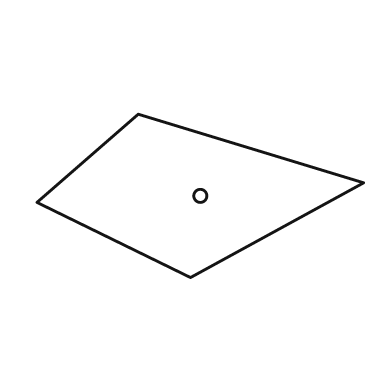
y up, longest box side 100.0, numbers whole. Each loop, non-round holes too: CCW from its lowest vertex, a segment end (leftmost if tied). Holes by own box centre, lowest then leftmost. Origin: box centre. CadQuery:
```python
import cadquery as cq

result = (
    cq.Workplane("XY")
    .moveTo(-3.0, -25.0)
    .lineTo(50.0, 4.0)
    .lineTo(-19.0, 25.0)
    .lineTo(-50.0, -2.0)
    .close()
    .moveTo(0.0, 0.0)
    .circle(2.0)
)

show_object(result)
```